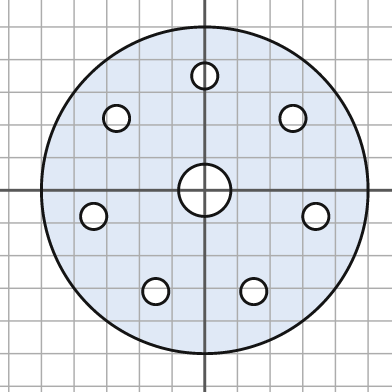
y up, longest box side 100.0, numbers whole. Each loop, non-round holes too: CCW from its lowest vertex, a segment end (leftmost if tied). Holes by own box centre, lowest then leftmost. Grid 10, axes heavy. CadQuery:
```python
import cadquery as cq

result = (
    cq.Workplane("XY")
    .moveTo(0.0, 0.0)
    .circle(50.0)
    .moveTo(-15.0, -31.0)
    .circle(4.0)
    .moveTo(15.0, -31.0)
    .circle(4.0)
    .moveTo(-34.0, -8.0)
    .circle(4.0)
    .moveTo(34.0, -8.0)
    .circle(4.0)
    .moveTo(0.0, 0.0)
    .circle(8.0)
    .moveTo(-27.0, 22.0)
    .circle(4.0)
    .moveTo(27.0, 22.0)
    .circle(4.0)
    .moveTo(0.0, 35.0)
    .circle(4.0)
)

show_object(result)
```